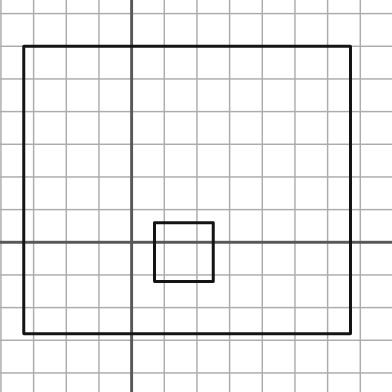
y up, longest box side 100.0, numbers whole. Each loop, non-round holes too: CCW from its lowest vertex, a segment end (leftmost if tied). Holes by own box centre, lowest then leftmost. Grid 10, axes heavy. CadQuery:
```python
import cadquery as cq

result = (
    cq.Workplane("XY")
    .moveTo(-33.0, -28.0)
    .lineTo(67.0, -28.0)
    .lineTo(67.0, 60.0)
    .lineTo(-33.0, 60.0)
    .close()
    .moveTo(7.0, -12.0)
    .lineTo(25.0, -12.0)
    .lineTo(25.0, 6.0)
    .lineTo(7.0, 6.0)
    .close()
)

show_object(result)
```